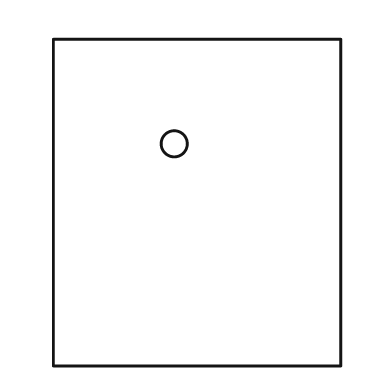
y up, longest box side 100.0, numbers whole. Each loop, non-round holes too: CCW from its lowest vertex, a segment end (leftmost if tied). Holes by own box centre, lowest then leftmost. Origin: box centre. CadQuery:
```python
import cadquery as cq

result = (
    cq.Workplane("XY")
    .moveTo(-44.0, -50.0)
    .lineTo(44.0, -50.0)
    .lineTo(44.0, 50.0)
    .lineTo(-44.0, 50.0)
    .close()
    .moveTo(-7.0, 18.0)
    .circle(4.0)
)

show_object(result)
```